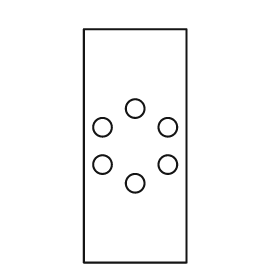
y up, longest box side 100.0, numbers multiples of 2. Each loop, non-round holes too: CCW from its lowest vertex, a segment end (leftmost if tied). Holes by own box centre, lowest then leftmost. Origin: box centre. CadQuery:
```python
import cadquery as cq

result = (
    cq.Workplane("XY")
    .moveTo(-22.0, -50.0)
    .lineTo(22.0, -50.0)
    .lineTo(22.0, 50.0)
    .lineTo(-22.0, 50.0)
    .close()
    .moveTo(0.0, -16.0)
    .circle(4.0)
    .moveTo(-14.0, -8.0)
    .circle(4.0)
    .moveTo(14.0, -8.0)
    .circle(4.0)
    .moveTo(-14.0, 8.0)
    .circle(4.0)
    .moveTo(14.0, 8.0)
    .circle(4.0)
    .moveTo(0.0, 16.0)
    .circle(4.0)
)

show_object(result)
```